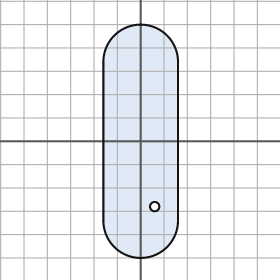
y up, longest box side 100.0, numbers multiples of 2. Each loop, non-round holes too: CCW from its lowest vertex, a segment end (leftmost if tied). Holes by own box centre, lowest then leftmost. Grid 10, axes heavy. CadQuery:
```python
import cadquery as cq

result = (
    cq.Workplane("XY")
    .moveTo(-16.0, -34.0)
    .threePointArc((0.0, -50.0), (16.0, -34.0))
    .lineTo(16.0, 34.0)
    .threePointArc((0.0, 50.0), (-16.0, 34.0))
    .close()
    .moveTo(6.0, -28.0)
    .circle(2.0)
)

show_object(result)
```